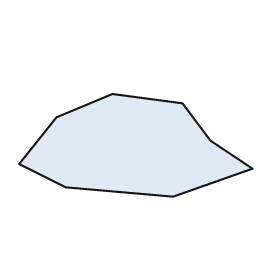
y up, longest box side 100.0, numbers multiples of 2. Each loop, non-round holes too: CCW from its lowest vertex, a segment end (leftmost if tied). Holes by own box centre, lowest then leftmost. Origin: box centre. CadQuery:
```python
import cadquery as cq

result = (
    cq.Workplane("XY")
    .moveTo(16.0, -22.0)
    .lineTo(50.0, -10.0)
    .lineTo(32.0, 2.0)
    .lineTo(20.0, 18.0)
    .lineTo(-10.0, 22.0)
    .lineTo(-34.0, 12.0)
    .lineTo(-50.0, -8.0)
    .lineTo(-30.0, -18.0)
    .close()
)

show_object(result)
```